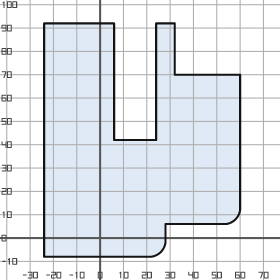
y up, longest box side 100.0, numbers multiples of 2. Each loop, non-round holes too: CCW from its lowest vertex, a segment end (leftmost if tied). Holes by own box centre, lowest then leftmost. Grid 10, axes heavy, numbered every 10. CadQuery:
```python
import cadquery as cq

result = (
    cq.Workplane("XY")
    .moveTo(-24.0, -8.0)
    .lineTo(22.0, -8.0)
    .threePointArc((26.0, -6.0), (28.0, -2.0))
    .lineTo(28.0, 6.0)
    .lineTo(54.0, 6.0)
    .threePointArc((58.0, 8.0), (60.0, 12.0))
    .lineTo(60.0, 70.0)
    .lineTo(32.0, 70.0)
    .lineTo(32.0, 92.0)
    .lineTo(24.0, 92.0)
    .lineTo(24.0, 42.0)
    .lineTo(6.0, 42.0)
    .lineTo(6.0, 92.0)
    .lineTo(-24.0, 92.0)
    .close()
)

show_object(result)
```